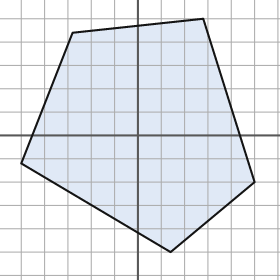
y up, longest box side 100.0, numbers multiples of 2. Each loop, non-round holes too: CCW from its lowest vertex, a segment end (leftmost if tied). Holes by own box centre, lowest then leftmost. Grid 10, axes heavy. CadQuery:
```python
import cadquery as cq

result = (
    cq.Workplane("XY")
    .moveTo(14.0, -50.0)
    .lineTo(50.0, -20.0)
    .lineTo(28.0, 50.0)
    .lineTo(-28.0, 44.0)
    .lineTo(-50.0, -12.0)
    .close()
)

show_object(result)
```